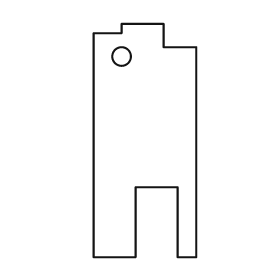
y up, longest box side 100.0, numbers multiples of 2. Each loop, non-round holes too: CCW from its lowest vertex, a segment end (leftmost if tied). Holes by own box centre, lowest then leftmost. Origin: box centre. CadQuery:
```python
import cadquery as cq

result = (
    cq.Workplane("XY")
    .moveTo(-22.0, -50.0)
    .lineTo(-4.0, -50.0)
    .lineTo(-4.0, -20.0)
    .lineTo(14.0, -20.0)
    .lineTo(14.0, -50.0)
    .lineTo(22.0, -50.0)
    .lineTo(22.0, 40.0)
    .lineTo(8.0, 40.0)
    .lineTo(8.0, 50.0)
    .lineTo(-10.0, 50.0)
    .lineTo(-10.0, 46.0)
    .lineTo(-22.0, 46.0)
    .close()
    .moveTo(-10.0, 36.0)
    .circle(4.0)
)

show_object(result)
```